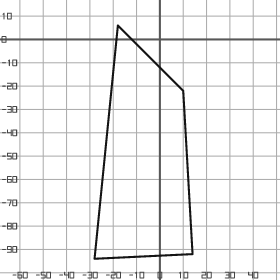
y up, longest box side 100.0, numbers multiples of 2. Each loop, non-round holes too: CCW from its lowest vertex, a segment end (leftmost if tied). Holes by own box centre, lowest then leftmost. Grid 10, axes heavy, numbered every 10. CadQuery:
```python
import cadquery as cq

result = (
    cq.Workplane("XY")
    .moveTo(-28.0, -94.0)
    .lineTo(14.0, -92.0)
    .lineTo(10.0, -22.0)
    .lineTo(-18.0, 6.0)
    .close()
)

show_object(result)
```